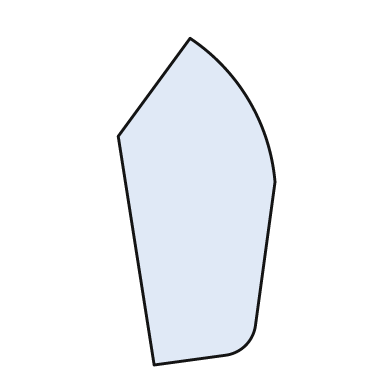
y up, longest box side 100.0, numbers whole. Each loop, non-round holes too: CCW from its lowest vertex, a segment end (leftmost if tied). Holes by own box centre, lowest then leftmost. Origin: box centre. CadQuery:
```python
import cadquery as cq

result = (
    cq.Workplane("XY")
    .moveTo(-13.0, -50.0)
    .lineTo(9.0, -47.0)
    .threePointArc((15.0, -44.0), (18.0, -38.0))
    .lineTo(24.0, 6.0)
    .threePointArc((16.0, 31.0), (-2.0, 50.0))
    .lineTo(-24.0, 20.0)
    .close()
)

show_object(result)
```